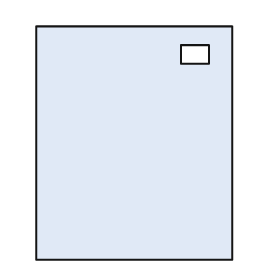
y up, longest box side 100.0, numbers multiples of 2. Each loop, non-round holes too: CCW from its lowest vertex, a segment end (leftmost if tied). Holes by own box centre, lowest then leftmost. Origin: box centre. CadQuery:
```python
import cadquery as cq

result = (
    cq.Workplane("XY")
    .moveTo(-42.0, -50.0)
    .lineTo(42.0, -50.0)
    .lineTo(42.0, 50.0)
    .lineTo(-42.0, 50.0)
    .close()
    .moveTo(20.0, 34.0)
    .lineTo(32.0, 34.0)
    .lineTo(32.0, 42.0)
    .lineTo(20.0, 42.0)
    .close()
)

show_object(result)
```